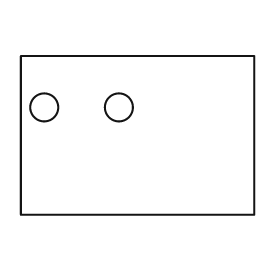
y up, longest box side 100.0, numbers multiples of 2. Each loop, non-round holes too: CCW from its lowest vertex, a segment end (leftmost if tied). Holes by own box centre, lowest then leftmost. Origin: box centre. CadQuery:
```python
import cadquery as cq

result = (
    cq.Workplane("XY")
    .moveTo(-50.0, -34.0)
    .lineTo(50.0, -34.0)
    .lineTo(50.0, 34.0)
    .lineTo(-50.0, 34.0)
    .close()
    .moveTo(-40.0, 12.0)
    .circle(6.0)
    .moveTo(-8.0, 12.0)
    .circle(6.0)
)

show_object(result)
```